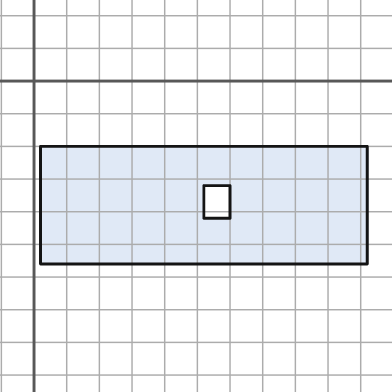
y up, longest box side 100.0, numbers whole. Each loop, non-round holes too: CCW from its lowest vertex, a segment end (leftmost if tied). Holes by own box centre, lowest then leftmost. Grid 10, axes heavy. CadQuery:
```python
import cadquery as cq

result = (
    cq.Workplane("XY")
    .moveTo(2.0, -56.0)
    .lineTo(102.0, -56.0)
    .lineTo(102.0, -20.0)
    .lineTo(2.0, -20.0)
    .close()
    .moveTo(52.0, -42.0)
    .lineTo(60.0, -42.0)
    .lineTo(60.0, -32.0)
    .lineTo(52.0, -32.0)
    .close()
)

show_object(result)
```